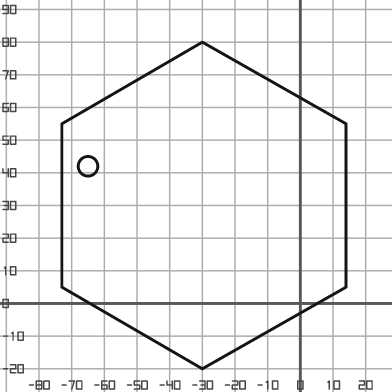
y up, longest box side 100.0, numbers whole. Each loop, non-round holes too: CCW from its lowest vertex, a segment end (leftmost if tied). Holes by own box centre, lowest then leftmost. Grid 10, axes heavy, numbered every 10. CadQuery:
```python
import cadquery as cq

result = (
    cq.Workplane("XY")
    .moveTo(-30.0, -20.0)
    .lineTo(14.0, 5.0)
    .lineTo(14.0, 55.0)
    .lineTo(-30.0, 80.0)
    .lineTo(-73.0, 55.0)
    .lineTo(-73.0, 5.0)
    .close()
    .moveTo(-65.0, 42.0)
    .circle(3.0)
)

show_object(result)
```